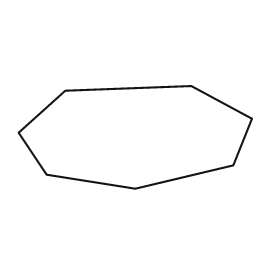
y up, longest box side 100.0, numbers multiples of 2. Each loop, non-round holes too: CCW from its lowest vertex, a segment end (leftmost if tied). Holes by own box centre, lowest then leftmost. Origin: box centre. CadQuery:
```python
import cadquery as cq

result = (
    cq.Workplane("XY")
    .moveTo(0.0, -22.0)
    .lineTo(42.0, -12.0)
    .lineTo(50.0, 8.0)
    .lineTo(24.0, 22.0)
    .lineTo(-30.0, 20.0)
    .lineTo(-50.0, 2.0)
    .lineTo(-38.0, -16.0)
    .close()
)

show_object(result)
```